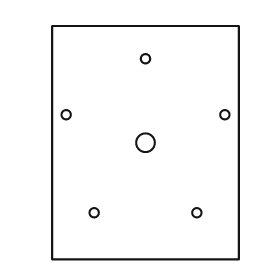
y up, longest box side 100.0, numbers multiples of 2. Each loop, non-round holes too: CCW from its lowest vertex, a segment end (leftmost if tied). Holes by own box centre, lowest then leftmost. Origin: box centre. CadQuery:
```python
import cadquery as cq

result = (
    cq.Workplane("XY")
    .moveTo(-40.0, -50.0)
    .lineTo(40.0, -50.0)
    .lineTo(40.0, 50.0)
    .lineTo(-40.0, 50.0)
    .close()
    .moveTo(-22.0, -30.0)
    .circle(2.0)
    .moveTo(22.0, -30.0)
    .circle(2.0)
    .moveTo(0.0, 0.0)
    .circle(4.0)
    .moveTo(-34.0, 12.0)
    .circle(2.0)
    .moveTo(34.0, 12.0)
    .circle(2.0)
    .moveTo(0.0, 36.0)
    .circle(2.0)
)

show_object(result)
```